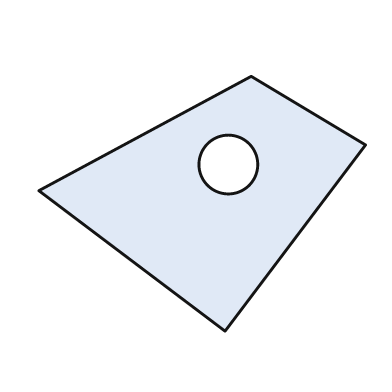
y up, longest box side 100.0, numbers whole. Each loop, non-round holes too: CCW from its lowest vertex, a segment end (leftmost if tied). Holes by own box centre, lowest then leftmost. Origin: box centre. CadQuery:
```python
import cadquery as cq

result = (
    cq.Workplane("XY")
    .moveTo(7.0, -39.0)
    .lineTo(50.0, 18.0)
    .lineTo(15.0, 39.0)
    .lineTo(-50.0, 4.0)
    .close()
    .moveTo(8.0, 12.0)
    .circle(9.0)
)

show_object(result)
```